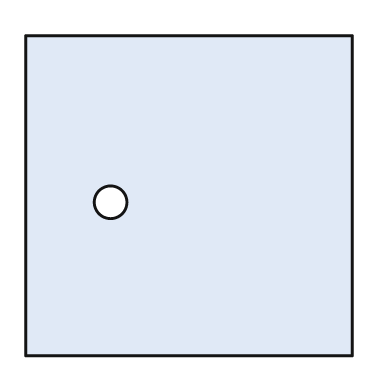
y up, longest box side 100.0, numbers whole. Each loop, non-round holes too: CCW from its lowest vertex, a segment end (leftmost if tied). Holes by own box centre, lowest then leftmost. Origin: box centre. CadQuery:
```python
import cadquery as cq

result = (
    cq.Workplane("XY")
    .moveTo(-50.0, -49.0)
    .lineTo(50.0, -49.0)
    .lineTo(50.0, 49.0)
    .lineTo(-50.0, 49.0)
    .close()
    .moveTo(-24.0, -2.0)
    .circle(5.0)
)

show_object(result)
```